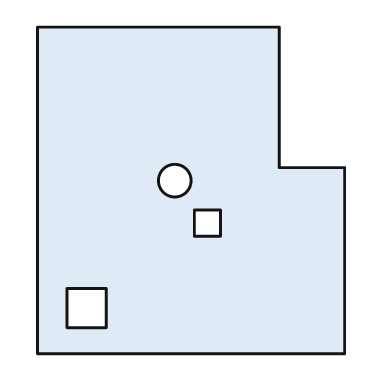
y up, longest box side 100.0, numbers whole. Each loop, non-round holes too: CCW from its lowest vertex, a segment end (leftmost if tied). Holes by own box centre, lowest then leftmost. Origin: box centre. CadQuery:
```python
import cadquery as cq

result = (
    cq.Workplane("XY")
    .moveTo(-47.0, -50.0)
    .lineTo(47.0, -50.0)
    .lineTo(47.0, 7.0)
    .lineTo(27.0, 7.0)
    .lineTo(27.0, 50.0)
    .lineTo(-47.0, 50.0)
    .close()
    .moveTo(-38.0, -42.0)
    .lineTo(-26.0, -42.0)
    .lineTo(-26.0, -30.0)
    .lineTo(-38.0, -30.0)
    .close()
    .moveTo(1.0, -14.0)
    .lineTo(9.0, -14.0)
    .lineTo(9.0, -6.0)
    .lineTo(1.0, -6.0)
    .close()
    .moveTo(-5.0, 3.0)
    .circle(5.0)
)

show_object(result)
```